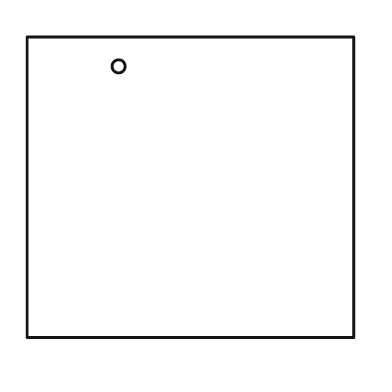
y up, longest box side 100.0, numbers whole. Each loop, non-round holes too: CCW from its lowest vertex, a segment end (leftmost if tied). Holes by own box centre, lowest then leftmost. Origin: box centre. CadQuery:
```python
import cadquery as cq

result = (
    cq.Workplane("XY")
    .moveTo(-50.0, -46.0)
    .lineTo(50.0, -46.0)
    .lineTo(50.0, 46.0)
    .lineTo(-50.0, 46.0)
    .close()
    .moveTo(-22.0, 37.0)
    .circle(2.0)
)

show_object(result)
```